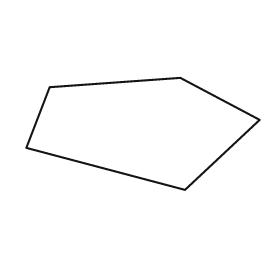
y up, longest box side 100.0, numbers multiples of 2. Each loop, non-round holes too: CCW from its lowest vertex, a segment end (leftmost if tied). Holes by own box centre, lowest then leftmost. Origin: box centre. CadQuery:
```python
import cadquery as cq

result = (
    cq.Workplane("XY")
    .moveTo(18.0, -24.0)
    .lineTo(50.0, 6.0)
    .lineTo(16.0, 24.0)
    .lineTo(-40.0, 20.0)
    .lineTo(-50.0, -6.0)
    .close()
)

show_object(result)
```